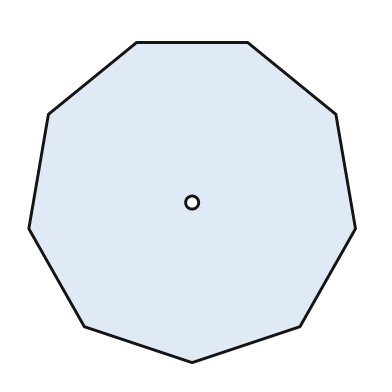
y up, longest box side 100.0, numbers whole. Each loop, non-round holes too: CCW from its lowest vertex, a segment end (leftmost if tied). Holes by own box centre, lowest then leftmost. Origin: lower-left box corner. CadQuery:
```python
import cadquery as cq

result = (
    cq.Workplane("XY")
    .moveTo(50.0, 0.0)
    .lineTo(83.0, 11.0)
    .lineTo(100.0, 41.0)
    .lineTo(94.0, 76.0)
    .lineTo(67.0, 98.0)
    .lineTo(33.0, 98.0)
    .lineTo(6.0, 76.0)
    .lineTo(0.0, 41.0)
    .lineTo(17.0, 11.0)
    .close()
    .moveTo(50.0, 49.0)
    .circle(2.0)
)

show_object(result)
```